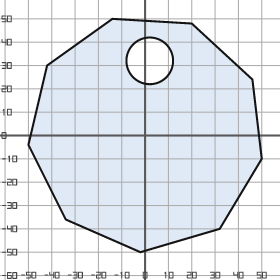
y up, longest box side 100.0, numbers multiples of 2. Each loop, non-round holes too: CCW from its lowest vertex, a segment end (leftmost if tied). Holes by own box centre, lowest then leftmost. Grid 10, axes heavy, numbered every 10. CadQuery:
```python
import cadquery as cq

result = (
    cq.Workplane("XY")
    .moveTo(-2.0, -50.0)
    .lineTo(32.0, -40.0)
    .lineTo(50.0, -10.0)
    .lineTo(46.0, 24.0)
    .lineTo(20.0, 48.0)
    .lineTo(-14.0, 50.0)
    .lineTo(-42.0, 30.0)
    .lineTo(-50.0, -4.0)
    .lineTo(-34.0, -36.0)
    .close()
    .moveTo(2.0, 32.0)
    .circle(10.0)
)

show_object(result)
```